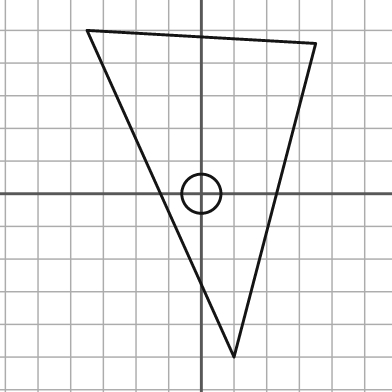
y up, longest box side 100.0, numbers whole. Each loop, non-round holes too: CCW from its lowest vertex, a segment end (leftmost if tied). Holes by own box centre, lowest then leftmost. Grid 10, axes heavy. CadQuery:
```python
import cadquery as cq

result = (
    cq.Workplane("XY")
    .moveTo(10.0, -50.0)
    .lineTo(35.0, 46.0)
    .lineTo(-35.0, 50.0)
    .close()
    .moveTo(0.0, 0.0)
    .circle(6.0)
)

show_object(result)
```